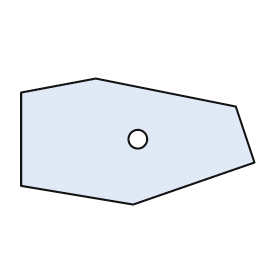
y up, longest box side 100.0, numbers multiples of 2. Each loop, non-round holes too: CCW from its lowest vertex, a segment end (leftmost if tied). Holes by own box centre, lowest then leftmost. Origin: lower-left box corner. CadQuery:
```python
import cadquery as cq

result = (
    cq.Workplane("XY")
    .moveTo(48.0, 0.0)
    .lineTo(100.0, 18.0)
    .lineTo(92.0, 42.0)
    .lineTo(32.0, 54.0)
    .lineTo(0.0, 48.0)
    .lineTo(0.0, 8.0)
    .close()
    .moveTo(50.0, 28.0)
    .circle(4.0)
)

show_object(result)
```